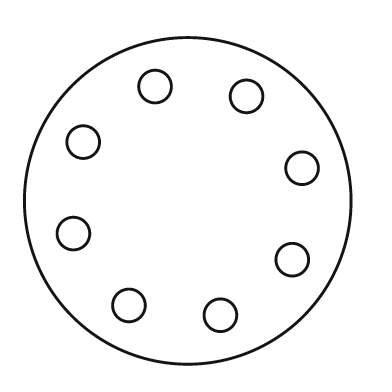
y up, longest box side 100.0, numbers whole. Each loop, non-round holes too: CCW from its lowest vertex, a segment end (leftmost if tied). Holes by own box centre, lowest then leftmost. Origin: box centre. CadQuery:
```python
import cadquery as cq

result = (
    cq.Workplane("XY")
    .moveTo(0.0, 0.0)
    .circle(50.0)
    .moveTo(10.0, -35.0)
    .circle(5.0)
    .moveTo(-18.0, -32.0)
    .circle(5.0)
    .moveTo(32.0, -18.0)
    .circle(5.0)
    .moveTo(-35.0, -10.0)
    .circle(5.0)
    .moveTo(35.0, 10.0)
    .circle(5.0)
    .moveTo(-32.0, 18.0)
    .circle(5.0)
    .moveTo(18.0, 32.0)
    .circle(5.0)
    .moveTo(-10.0, 35.0)
    .circle(5.0)
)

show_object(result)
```